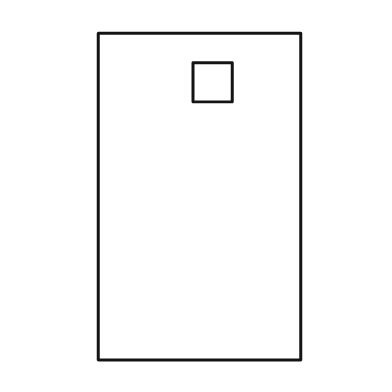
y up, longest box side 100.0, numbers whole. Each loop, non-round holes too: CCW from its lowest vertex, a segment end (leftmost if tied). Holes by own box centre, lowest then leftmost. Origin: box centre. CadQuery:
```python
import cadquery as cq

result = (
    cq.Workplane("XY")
    .moveTo(-31.0, -50.0)
    .lineTo(31.0, -50.0)
    .lineTo(31.0, 50.0)
    .lineTo(-31.0, 50.0)
    .close()
    .moveTo(-2.0, 29.0)
    .lineTo(10.0, 29.0)
    .lineTo(10.0, 41.0)
    .lineTo(-2.0, 41.0)
    .close()
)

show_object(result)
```